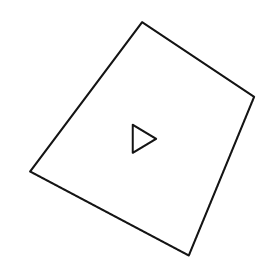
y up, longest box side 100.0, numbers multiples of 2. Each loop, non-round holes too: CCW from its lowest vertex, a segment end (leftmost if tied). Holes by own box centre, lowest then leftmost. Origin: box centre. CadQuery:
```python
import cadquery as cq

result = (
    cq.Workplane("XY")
    .moveTo(20.0, -50.0)
    .lineTo(48.0, 18.0)
    .lineTo(0.0, 50.0)
    .lineTo(-48.0, -14.0)
    .close()
    .moveTo(-4.0, -6.0)
    .lineTo(6.0, 0.0)
    .lineTo(-4.0, 6.0)
    .close()
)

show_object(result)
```